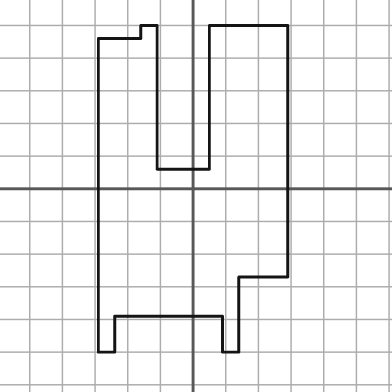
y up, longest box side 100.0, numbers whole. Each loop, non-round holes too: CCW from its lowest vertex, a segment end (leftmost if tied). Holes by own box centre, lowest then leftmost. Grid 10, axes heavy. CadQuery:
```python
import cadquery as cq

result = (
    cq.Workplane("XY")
    .moveTo(-29.0, -50.0)
    .lineTo(-24.0, -50.0)
    .lineTo(-24.0, -39.0)
    .lineTo(9.0, -39.0)
    .lineTo(9.0, -50.0)
    .lineTo(14.0, -50.0)
    .lineTo(14.0, -27.0)
    .lineTo(29.0, -27.0)
    .lineTo(29.0, 50.0)
    .lineTo(5.0, 50.0)
    .lineTo(5.0, 6.0)
    .lineTo(-11.0, 6.0)
    .lineTo(-11.0, 50.0)
    .lineTo(-16.0, 50.0)
    .lineTo(-16.0, 46.0)
    .lineTo(-29.0, 46.0)
    .close()
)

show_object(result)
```